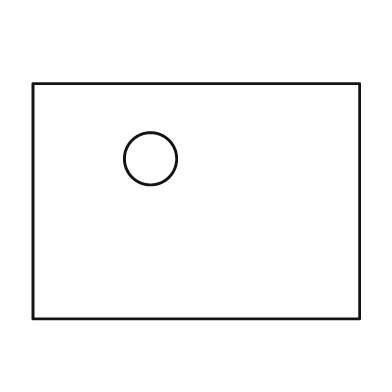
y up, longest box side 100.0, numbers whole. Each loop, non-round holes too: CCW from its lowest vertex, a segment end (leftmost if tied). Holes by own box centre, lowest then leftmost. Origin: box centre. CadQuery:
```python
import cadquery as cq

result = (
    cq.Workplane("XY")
    .moveTo(-50.0, -36.0)
    .lineTo(50.0, -36.0)
    .lineTo(50.0, 36.0)
    .lineTo(-50.0, 36.0)
    .close()
    .moveTo(-14.0, 13.0)
    .circle(8.0)
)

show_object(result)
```